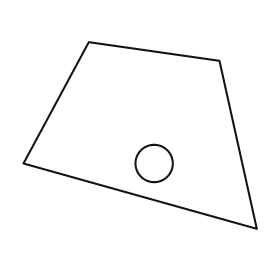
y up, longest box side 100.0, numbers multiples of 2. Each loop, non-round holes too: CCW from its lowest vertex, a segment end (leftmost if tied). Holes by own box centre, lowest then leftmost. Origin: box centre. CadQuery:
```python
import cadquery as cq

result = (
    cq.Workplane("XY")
    .moveTo(50.0, -40.0)
    .lineTo(34.0, 32.0)
    .lineTo(-22.0, 40.0)
    .lineTo(-50.0, -12.0)
    .close()
    .moveTo(6.0, -12.0)
    .circle(8.0)
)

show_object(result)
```